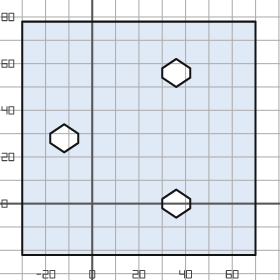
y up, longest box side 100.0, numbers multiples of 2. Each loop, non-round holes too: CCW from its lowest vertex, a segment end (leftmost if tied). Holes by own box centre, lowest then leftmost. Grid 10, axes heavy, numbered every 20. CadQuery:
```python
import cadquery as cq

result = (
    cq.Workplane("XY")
    .moveTo(-30.0, -22.0)
    .lineTo(70.0, -22.0)
    .lineTo(70.0, 78.0)
    .lineTo(-30.0, 78.0)
    .close()
    .moveTo(36.0, -6.0)
    .lineTo(42.0, -2.0)
    .lineTo(42.0, 2.0)
    .lineTo(36.0, 6.0)
    .lineTo(30.0, 2.0)
    .lineTo(30.0, -2.0)
    .close()
    .moveTo(-12.0, 22.0)
    .lineTo(-6.0, 26.0)
    .lineTo(-6.0, 30.0)
    .lineTo(-12.0, 34.0)
    .lineTo(-18.0, 30.0)
    .lineTo(-18.0, 26.0)
    .close()
    .moveTo(36.0, 50.0)
    .lineTo(42.0, 54.0)
    .lineTo(42.0, 58.0)
    .lineTo(36.0, 62.0)
    .lineTo(30.0, 58.0)
    .lineTo(30.0, 54.0)
    .close()
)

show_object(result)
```